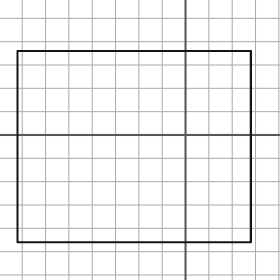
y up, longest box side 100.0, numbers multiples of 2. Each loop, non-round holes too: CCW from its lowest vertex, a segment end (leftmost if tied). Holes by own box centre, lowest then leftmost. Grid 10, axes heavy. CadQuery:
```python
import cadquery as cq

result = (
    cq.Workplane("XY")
    .moveTo(-72.0, -46.0)
    .lineTo(28.0, -46.0)
    .lineTo(28.0, 36.0)
    .lineTo(-72.0, 36.0)
    .close()
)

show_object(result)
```